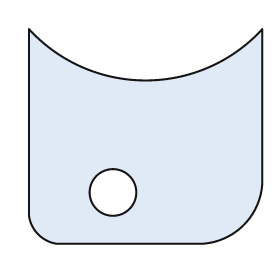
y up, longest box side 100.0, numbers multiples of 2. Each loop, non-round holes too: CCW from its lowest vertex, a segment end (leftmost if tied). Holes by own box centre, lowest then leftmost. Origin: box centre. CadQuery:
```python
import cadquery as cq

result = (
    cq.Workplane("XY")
    .moveTo(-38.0, -46.0)
    .lineTo(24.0, -46.0)
    .threePointArc((42.0, -38.0), (50.0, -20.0))
    .lineTo(50.0, 46.0)
    .threePointArc((0.0, 24.0), (-50.0, 46.0))
    .lineTo(-50.0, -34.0)
    .threePointArc((-46.0, -42.0), (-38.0, -46.0))
    .close()
    .moveTo(-14.0, -24.0)
    .circle(10.0)
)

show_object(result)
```